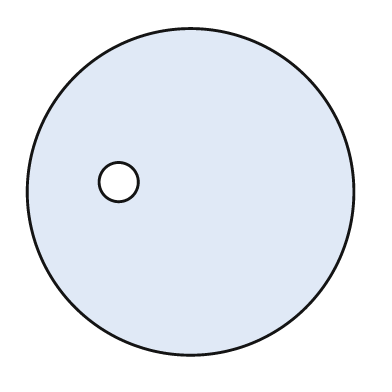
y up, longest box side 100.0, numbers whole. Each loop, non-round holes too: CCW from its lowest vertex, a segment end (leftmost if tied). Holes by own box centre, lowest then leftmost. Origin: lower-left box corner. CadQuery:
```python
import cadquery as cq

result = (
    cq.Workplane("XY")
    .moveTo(50.0, 50.0)
    .circle(50.0)
    .moveTo(28.0, 53.0)
    .circle(6.0)
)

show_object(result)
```